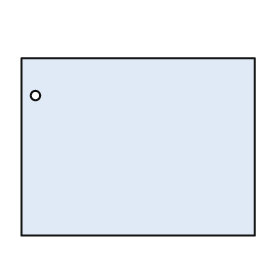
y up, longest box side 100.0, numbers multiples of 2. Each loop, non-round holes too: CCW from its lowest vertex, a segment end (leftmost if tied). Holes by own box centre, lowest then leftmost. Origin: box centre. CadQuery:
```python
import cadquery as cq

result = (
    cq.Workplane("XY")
    .moveTo(-50.0, -38.0)
    .lineTo(50.0, -38.0)
    .lineTo(50.0, 38.0)
    .lineTo(-50.0, 38.0)
    .close()
    .moveTo(-44.0, 22.0)
    .circle(2.0)
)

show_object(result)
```